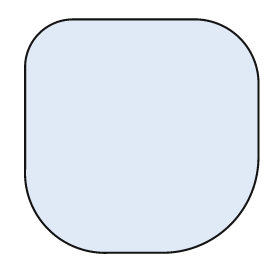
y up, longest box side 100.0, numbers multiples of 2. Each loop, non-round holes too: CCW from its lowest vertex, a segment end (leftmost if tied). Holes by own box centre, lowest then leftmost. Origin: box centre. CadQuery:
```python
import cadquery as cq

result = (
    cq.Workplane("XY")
    .moveTo(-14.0, -50.0)
    .lineTo(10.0, -50.0)
    .threePointArc((38.0, -38.0), (50.0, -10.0))
    .lineTo(50.0, 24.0)
    .threePointArc((42.0, 42.0), (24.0, 50.0))
    .lineTo(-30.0, 50.0)
    .threePointArc((-44.0, 44.0), (-50.0, 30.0))
    .lineTo(-50.0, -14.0)
    .threePointArc((-40.0, -40.0), (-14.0, -50.0))
    .close()
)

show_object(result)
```